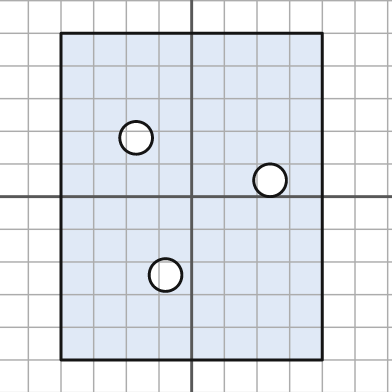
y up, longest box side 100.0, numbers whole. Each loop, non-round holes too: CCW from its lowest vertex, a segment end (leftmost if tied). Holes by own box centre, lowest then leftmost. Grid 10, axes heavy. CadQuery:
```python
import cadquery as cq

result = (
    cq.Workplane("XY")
    .moveTo(-40.0, -50.0)
    .lineTo(40.0, -50.0)
    .lineTo(40.0, 50.0)
    .lineTo(-40.0, 50.0)
    .close()
    .moveTo(-8.0, -24.0)
    .circle(5.0)
    .moveTo(24.0, 5.0)
    .circle(5.0)
    .moveTo(-17.0, 18.0)
    .circle(5.0)
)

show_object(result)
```